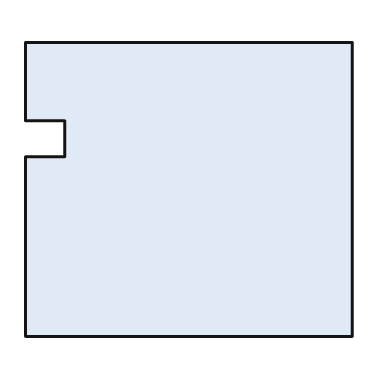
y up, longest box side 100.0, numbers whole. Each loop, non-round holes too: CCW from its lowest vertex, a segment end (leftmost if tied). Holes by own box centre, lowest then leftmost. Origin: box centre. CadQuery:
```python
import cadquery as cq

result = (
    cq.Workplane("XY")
    .moveTo(-50.0, -45.0)
    .lineTo(50.0, -45.0)
    .lineTo(50.0, 45.0)
    .lineTo(-50.0, 45.0)
    .lineTo(-50.0, 21.0)
    .lineTo(-38.0, 21.0)
    .lineTo(-38.0, 10.0)
    .lineTo(-50.0, 10.0)
    .close()
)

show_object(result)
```